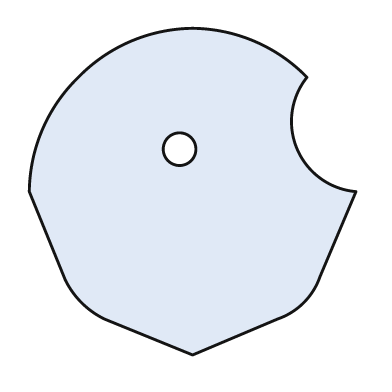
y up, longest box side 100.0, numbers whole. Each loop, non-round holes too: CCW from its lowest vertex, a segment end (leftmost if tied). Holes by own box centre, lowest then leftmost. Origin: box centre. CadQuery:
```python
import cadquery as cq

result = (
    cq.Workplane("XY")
    .moveTo(0.0, -50.0)
    .lineTo(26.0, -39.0)
    .threePointArc((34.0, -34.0), (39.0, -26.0))
    .lineTo(50.0, 0.0)
    .threePointArc((32.0, 13.0), (35.0, 35.0))
    .threePointArc((19.0, 46.0), (0.0, 50.0))
    .threePointArc((-19.0, 46.0), (-35.0, 35.0))
    .threePointArc((-46.0, 19.0), (-50.0, 0.0))
    .lineTo(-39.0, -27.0)
    .threePointArc((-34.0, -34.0), (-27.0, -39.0))
    .close()
    .moveTo(-4.0, 13.0)
    .circle(5.0)
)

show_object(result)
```